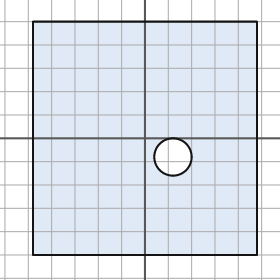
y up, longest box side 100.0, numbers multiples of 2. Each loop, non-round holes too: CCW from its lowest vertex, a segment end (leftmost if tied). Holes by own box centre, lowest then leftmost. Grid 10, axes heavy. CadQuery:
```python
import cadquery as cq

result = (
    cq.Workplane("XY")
    .moveTo(-48.0, -50.0)
    .lineTo(48.0, -50.0)
    .lineTo(48.0, 50.0)
    .lineTo(-48.0, 50.0)
    .close()
    .moveTo(12.0, -8.0)
    .circle(8.0)
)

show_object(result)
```